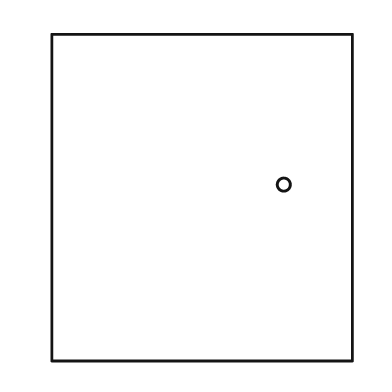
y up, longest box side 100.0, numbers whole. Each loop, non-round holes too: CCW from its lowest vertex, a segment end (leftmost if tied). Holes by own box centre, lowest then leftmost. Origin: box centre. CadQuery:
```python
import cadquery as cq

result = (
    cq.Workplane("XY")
    .moveTo(-46.0, -50.0)
    .lineTo(46.0, -50.0)
    .lineTo(46.0, 50.0)
    .lineTo(-46.0, 50.0)
    .close()
    .moveTo(25.0, 4.0)
    .circle(2.0)
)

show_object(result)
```